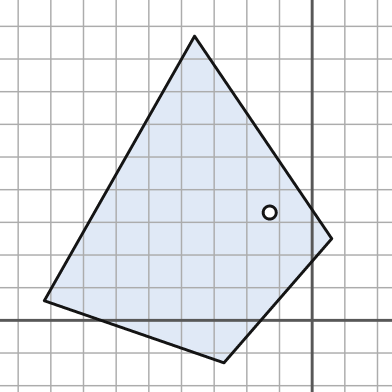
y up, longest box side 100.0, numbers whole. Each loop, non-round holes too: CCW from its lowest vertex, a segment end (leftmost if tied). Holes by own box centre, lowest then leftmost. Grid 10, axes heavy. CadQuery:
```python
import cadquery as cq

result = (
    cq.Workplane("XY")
    .moveTo(-27.0, -13.0)
    .lineTo(6.0, 25.0)
    .lineTo(-36.0, 87.0)
    .lineTo(-82.0, 6.0)
    .close()
    .moveTo(-13.0, 33.0)
    .circle(2.0)
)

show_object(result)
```